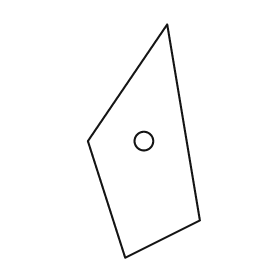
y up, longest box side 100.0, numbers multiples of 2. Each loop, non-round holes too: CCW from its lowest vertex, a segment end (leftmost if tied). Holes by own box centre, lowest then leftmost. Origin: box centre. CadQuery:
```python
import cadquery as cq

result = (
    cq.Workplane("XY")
    .moveTo(-8.0, -50.0)
    .lineTo(24.0, -34.0)
    .lineTo(10.0, 50.0)
    .lineTo(-24.0, 0.0)
    .close()
    .moveTo(0.0, 0.0)
    .circle(4.0)
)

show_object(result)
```